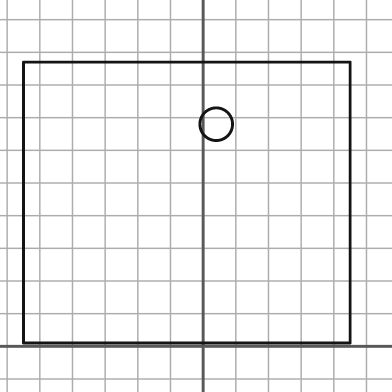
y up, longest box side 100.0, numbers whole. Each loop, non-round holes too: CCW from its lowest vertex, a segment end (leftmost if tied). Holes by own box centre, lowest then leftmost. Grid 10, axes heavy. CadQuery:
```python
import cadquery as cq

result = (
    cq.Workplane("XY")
    .moveTo(-55.0, 1.0)
    .lineTo(45.0, 1.0)
    .lineTo(45.0, 87.0)
    .lineTo(-55.0, 87.0)
    .close()
    .moveTo(4.0, 68.0)
    .circle(5.0)
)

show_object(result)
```